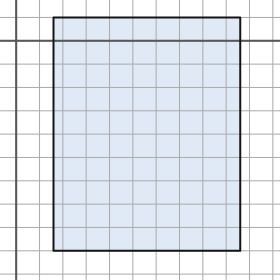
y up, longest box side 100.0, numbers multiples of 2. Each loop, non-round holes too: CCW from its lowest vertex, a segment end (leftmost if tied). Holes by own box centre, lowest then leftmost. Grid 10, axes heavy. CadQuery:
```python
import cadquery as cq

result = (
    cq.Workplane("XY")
    .moveTo(16.0, -90.0)
    .lineTo(96.0, -90.0)
    .lineTo(96.0, 10.0)
    .lineTo(16.0, 10.0)
    .close()
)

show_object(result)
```